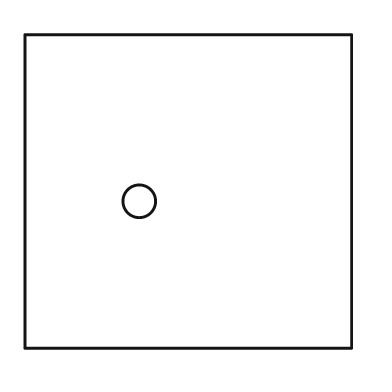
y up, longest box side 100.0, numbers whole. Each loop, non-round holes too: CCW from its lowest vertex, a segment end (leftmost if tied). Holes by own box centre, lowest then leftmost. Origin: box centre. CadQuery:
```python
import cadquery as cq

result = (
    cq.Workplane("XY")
    .moveTo(-50.0, -48.0)
    .lineTo(50.0, -48.0)
    .lineTo(50.0, 48.0)
    .lineTo(-50.0, 48.0)
    .close()
    .moveTo(-15.0, -3.0)
    .circle(5.0)
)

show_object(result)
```